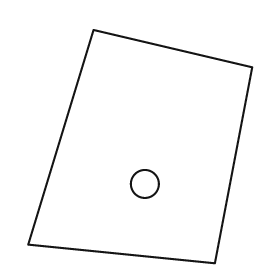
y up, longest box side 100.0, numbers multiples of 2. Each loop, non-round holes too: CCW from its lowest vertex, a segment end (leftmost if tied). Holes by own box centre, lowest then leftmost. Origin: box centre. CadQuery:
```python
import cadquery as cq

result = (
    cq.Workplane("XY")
    .moveTo(32.0, -50.0)
    .lineTo(48.0, 34.0)
    .lineTo(-20.0, 50.0)
    .lineTo(-48.0, -42.0)
    .close()
    .moveTo(2.0, -16.0)
    .circle(6.0)
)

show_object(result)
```